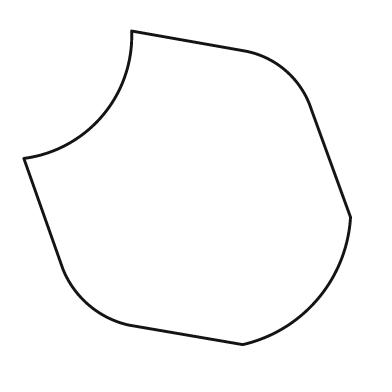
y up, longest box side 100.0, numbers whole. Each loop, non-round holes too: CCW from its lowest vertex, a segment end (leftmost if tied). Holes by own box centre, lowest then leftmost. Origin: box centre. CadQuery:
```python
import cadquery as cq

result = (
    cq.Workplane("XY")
    .moveTo(17.0, -48.0)
    .threePointArc((40.0, -34.0), (50.0, -9.0))
    .lineTo(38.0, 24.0)
    .threePointArc((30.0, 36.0), (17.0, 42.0))
    .lineTo(-17.0, 48.0)
    .threePointArc((-26.0, 22.0), (-50.0, 9.0))
    .lineTo(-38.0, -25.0)
    .threePointArc((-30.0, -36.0), (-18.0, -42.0))
    .close()
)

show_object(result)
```